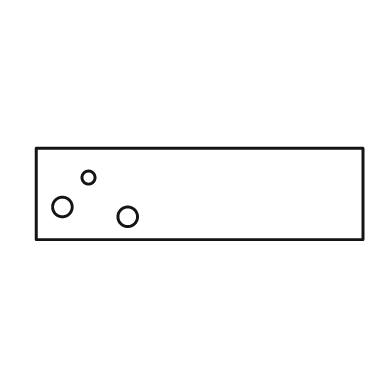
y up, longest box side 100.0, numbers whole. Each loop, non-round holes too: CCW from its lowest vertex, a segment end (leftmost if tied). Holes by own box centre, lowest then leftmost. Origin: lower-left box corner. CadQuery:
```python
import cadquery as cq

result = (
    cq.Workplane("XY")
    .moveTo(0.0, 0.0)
    .lineTo(100.0, 0.0)
    .lineTo(100.0, 28.0)
    .lineTo(0.0, 28.0)
    .close()
    .moveTo(28.0, 7.0)
    .circle(3.0)
    .moveTo(8.0, 10.0)
    .circle(3.0)
    .moveTo(16.0, 19.0)
    .circle(2.0)
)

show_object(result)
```